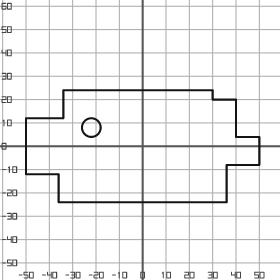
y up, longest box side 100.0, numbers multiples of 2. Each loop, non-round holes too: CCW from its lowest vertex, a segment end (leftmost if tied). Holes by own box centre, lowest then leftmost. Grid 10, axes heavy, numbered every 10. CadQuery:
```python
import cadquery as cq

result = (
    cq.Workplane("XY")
    .moveTo(-36.0, -24.0)
    .lineTo(36.0, -24.0)
    .lineTo(36.0, -8.0)
    .lineTo(50.0, -8.0)
    .lineTo(50.0, 4.0)
    .lineTo(40.0, 4.0)
    .lineTo(40.0, 20.0)
    .lineTo(30.0, 20.0)
    .lineTo(30.0, 24.0)
    .lineTo(-34.0, 24.0)
    .lineTo(-34.0, 12.0)
    .lineTo(-50.0, 12.0)
    .lineTo(-50.0, -12.0)
    .lineTo(-36.0, -12.0)
    .close()
    .moveTo(-22.0, 8.0)
    .circle(4.0)
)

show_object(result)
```